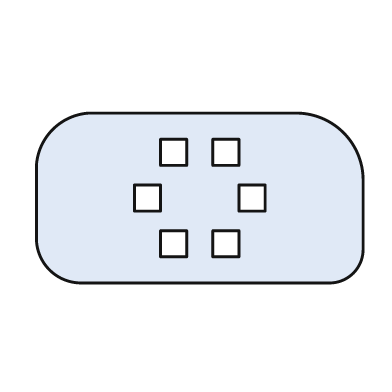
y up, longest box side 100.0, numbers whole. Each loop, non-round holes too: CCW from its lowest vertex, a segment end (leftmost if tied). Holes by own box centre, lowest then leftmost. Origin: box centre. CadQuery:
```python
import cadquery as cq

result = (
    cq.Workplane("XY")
    .moveTo(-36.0, -26.0)
    .lineTo(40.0, -26.0)
    .threePointArc((47.0, -23.0), (50.0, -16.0))
    .lineTo(50.0, 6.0)
    .threePointArc((44.0, 20.0), (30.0, 26.0))
    .lineTo(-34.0, 26.0)
    .threePointArc((-45.0, 21.0), (-50.0, 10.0))
    .lineTo(-50.0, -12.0)
    .threePointArc((-46.0, -22.0), (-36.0, -26.0))
    .close()
    .moveTo(-12.0, -18.0)
    .lineTo(-4.0, -18.0)
    .lineTo(-4.0, -10.0)
    .lineTo(-12.0, -10.0)
    .close()
    .moveTo(4.0, -18.0)
    .lineTo(12.0, -18.0)
    .lineTo(12.0, -10.0)
    .lineTo(4.0, -10.0)
    .close()
    .moveTo(-20.0, -4.0)
    .lineTo(-12.0, -4.0)
    .lineTo(-12.0, 4.0)
    .lineTo(-20.0, 4.0)
    .close()
    .moveTo(12.0, -4.0)
    .lineTo(20.0, -4.0)
    .lineTo(20.0, 4.0)
    .lineTo(12.0, 4.0)
    .close()
    .moveTo(-12.0, 10.0)
    .lineTo(-4.0, 10.0)
    .lineTo(-4.0, 18.0)
    .lineTo(-12.0, 18.0)
    .close()
    .moveTo(4.0, 10.0)
    .lineTo(12.0, 10.0)
    .lineTo(12.0, 18.0)
    .lineTo(4.0, 18.0)
    .close()
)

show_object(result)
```